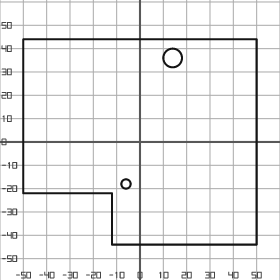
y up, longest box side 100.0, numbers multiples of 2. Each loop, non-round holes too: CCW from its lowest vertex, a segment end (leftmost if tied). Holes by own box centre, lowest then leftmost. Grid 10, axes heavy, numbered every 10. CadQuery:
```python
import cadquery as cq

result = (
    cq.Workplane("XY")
    .moveTo(-12.0, -44.0)
    .lineTo(50.0, -44.0)
    .lineTo(50.0, 44.0)
    .lineTo(-50.0, 44.0)
    .lineTo(-50.0, -22.0)
    .lineTo(-12.0, -22.0)
    .close()
    .moveTo(-6.0, -18.0)
    .circle(2.0)
    .moveTo(14.0, 36.0)
    .circle(4.0)
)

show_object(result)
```